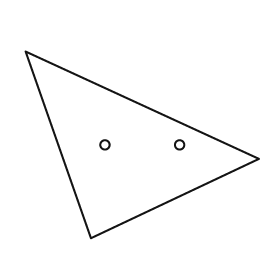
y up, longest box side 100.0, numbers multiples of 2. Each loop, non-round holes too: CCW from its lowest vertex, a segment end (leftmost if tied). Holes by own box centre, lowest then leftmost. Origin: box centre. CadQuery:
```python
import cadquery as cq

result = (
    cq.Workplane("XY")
    .moveTo(-22.0, -40.0)
    .lineTo(50.0, -6.0)
    .lineTo(-50.0, 40.0)
    .close()
    .moveTo(-16.0, 0.0)
    .circle(2.0)
    .moveTo(16.0, 0.0)
    .circle(2.0)
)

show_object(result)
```